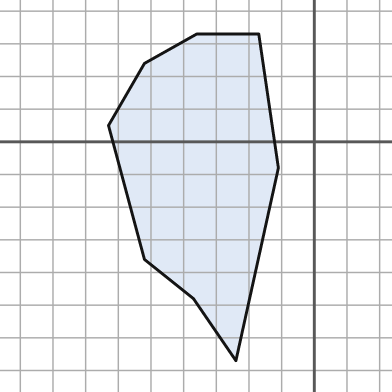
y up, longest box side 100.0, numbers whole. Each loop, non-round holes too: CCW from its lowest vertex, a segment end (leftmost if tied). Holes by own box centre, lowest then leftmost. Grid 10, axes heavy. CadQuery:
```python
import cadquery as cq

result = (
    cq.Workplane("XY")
    .moveTo(-24.0, -67.0)
    .lineTo(-11.0, -8.0)
    .lineTo(-17.0, 33.0)
    .lineTo(-36.0, 33.0)
    .lineTo(-52.0, 24.0)
    .lineTo(-63.0, 5.0)
    .lineTo(-52.0, -36.0)
    .lineTo(-37.0, -48.0)
    .close()
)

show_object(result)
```